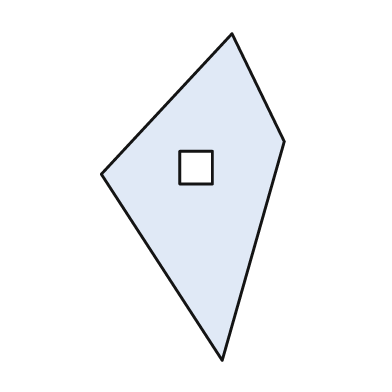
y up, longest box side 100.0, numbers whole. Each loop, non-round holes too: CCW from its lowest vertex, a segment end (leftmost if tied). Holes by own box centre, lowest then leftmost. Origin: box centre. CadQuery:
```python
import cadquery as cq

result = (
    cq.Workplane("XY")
    .moveTo(9.0, -50.0)
    .lineTo(28.0, 17.0)
    .lineTo(12.0, 50.0)
    .lineTo(-28.0, 7.0)
    .close()
    .moveTo(-4.0, 4.0)
    .lineTo(6.0, 4.0)
    .lineTo(6.0, 14.0)
    .lineTo(-4.0, 14.0)
    .close()
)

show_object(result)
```